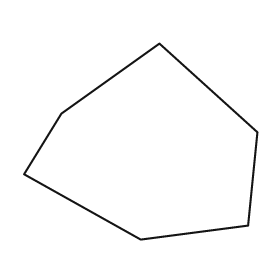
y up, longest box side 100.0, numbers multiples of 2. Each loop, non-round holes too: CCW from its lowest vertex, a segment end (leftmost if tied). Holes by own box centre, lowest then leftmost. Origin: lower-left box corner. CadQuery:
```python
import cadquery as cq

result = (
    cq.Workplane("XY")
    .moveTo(50.0, 0.0)
    .lineTo(96.0, 6.0)
    .lineTo(100.0, 46.0)
    .lineTo(58.0, 84.0)
    .lineTo(16.0, 54.0)
    .lineTo(0.0, 28.0)
    .close()
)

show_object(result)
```